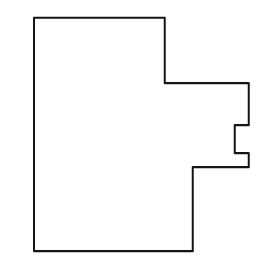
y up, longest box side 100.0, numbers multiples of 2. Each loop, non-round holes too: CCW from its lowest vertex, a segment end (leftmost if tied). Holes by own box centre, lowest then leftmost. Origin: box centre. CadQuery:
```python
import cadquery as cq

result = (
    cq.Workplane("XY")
    .moveTo(-46.0, -50.0)
    .lineTo(22.0, -50.0)
    .lineTo(22.0, -14.0)
    .lineTo(46.0, -14.0)
    .lineTo(46.0, -8.0)
    .lineTo(40.0, -8.0)
    .lineTo(40.0, 4.0)
    .lineTo(46.0, 4.0)
    .lineTo(46.0, 22.0)
    .lineTo(10.0, 22.0)
    .lineTo(10.0, 50.0)
    .lineTo(-46.0, 50.0)
    .close()
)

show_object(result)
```